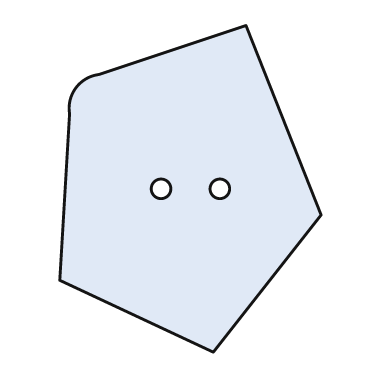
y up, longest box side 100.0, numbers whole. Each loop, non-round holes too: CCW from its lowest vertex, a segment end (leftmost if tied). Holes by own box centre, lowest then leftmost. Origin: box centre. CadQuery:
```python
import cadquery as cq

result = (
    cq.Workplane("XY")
    .moveTo(7.0, -50.0)
    .lineTo(40.0, -8.0)
    .lineTo(17.0, 50.0)
    .lineTo(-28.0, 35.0)
    .threePointArc((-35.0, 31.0), (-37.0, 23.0))
    .lineTo(-40.0, -28.0)
    .close()
    .moveTo(-9.0, 0.0)
    .circle(3.0)
    .moveTo(9.0, 0.0)
    .circle(3.0)
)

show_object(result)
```